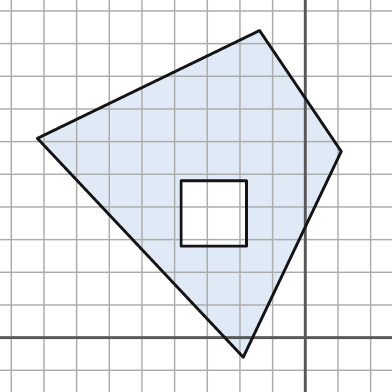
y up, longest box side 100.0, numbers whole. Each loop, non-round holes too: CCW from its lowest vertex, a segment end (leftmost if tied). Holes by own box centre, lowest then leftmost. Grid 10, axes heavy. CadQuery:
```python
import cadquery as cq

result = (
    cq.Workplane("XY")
    .moveTo(-19.0, -6.0)
    .lineTo(11.0, 57.0)
    .lineTo(-14.0, 94.0)
    .lineTo(-82.0, 61.0)
    .close()
    .moveTo(-38.0, 28.0)
    .lineTo(-18.0, 28.0)
    .lineTo(-18.0, 48.0)
    .lineTo(-38.0, 48.0)
    .close()
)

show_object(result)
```